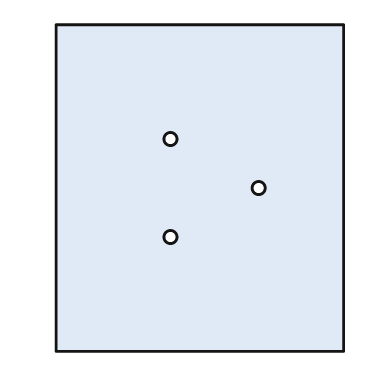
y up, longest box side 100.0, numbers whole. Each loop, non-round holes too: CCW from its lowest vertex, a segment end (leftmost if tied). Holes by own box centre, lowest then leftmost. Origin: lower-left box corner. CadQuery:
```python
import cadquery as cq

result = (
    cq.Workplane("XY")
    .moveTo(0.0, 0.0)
    .lineTo(88.0, 0.0)
    .lineTo(88.0, 100.0)
    .lineTo(0.0, 100.0)
    .close()
    .moveTo(35.0, 35.0)
    .circle(2.0)
    .moveTo(62.0, 50.0)
    .circle(2.0)
    .moveTo(35.0, 65.0)
    .circle(2.0)
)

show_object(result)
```